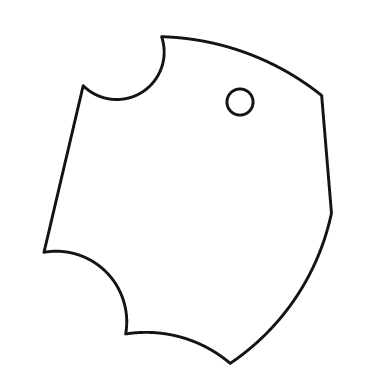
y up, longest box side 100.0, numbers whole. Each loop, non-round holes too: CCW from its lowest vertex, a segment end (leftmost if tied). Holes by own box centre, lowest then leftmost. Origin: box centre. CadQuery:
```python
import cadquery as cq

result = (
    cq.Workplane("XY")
    .moveTo(13.0, -50.0)
    .threePointArc((33.0, -30.0), (44.0, -4.0))
    .lineTo(41.0, 32.0)
    .threePointArc((18.0, 45.0), (-8.0, 50.0))
    .threePointArc((-14.0, 33.0), (-32.0, 35.0))
    .lineTo(-44.0, -16.0)
    .threePointArc((-25.0, -22.0), (-19.0, -41.0))
    .threePointArc((-2.0, -42.0), (13.0, -50.0))
    .close()
    .moveTo(16.0, 30.0)
    .circle(4.0)
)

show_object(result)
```